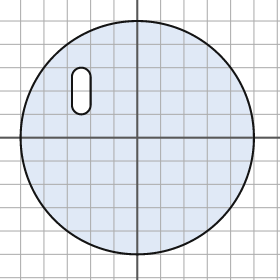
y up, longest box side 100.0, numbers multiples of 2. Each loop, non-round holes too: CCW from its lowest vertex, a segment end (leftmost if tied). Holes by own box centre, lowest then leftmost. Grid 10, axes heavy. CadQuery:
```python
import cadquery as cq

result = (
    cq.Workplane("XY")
    .moveTo(0.0, 0.0)
    .circle(50.0)
    .moveTo(-28.0, 14.0)
    .threePointArc((-24.0, 10.0), (-20.0, 14.0))
    .lineTo(-20.0, 26.0)
    .threePointArc((-24.0, 30.0), (-28.0, 26.0))
    .close()
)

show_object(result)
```